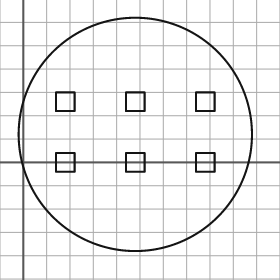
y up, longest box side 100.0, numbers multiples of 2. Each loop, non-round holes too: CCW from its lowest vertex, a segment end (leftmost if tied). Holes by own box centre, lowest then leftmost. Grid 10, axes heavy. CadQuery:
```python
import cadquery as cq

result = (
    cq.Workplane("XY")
    .moveTo(48.0, 12.0)
    .circle(50.0)
    .moveTo(14.0, -4.0)
    .lineTo(22.0, -4.0)
    .lineTo(22.0, 4.0)
    .lineTo(14.0, 4.0)
    .close()
    .moveTo(44.0, -4.0)
    .lineTo(52.0, -4.0)
    .lineTo(52.0, 4.0)
    .lineTo(44.0, 4.0)
    .close()
    .moveTo(74.0, -4.0)
    .lineTo(82.0, -4.0)
    .lineTo(82.0, 4.0)
    .lineTo(74.0, 4.0)
    .close()
    .moveTo(14.0, 22.0)
    .lineTo(22.0, 22.0)
    .lineTo(22.0, 30.0)
    .lineTo(14.0, 30.0)
    .close()
    .moveTo(44.0, 22.0)
    .lineTo(52.0, 22.0)
    .lineTo(52.0, 30.0)
    .lineTo(44.0, 30.0)
    .close()
    .moveTo(74.0, 22.0)
    .lineTo(82.0, 22.0)
    .lineTo(82.0, 30.0)
    .lineTo(74.0, 30.0)
    .close()
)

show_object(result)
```